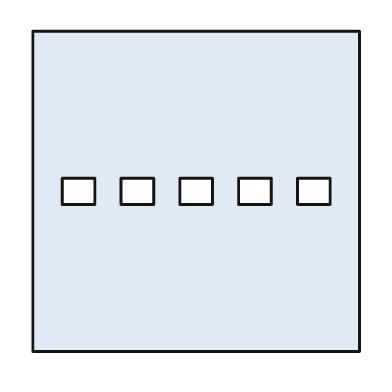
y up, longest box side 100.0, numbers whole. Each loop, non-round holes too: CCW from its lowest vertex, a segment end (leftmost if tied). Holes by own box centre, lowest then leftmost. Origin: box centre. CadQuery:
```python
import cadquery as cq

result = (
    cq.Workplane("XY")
    .moveTo(-50.0, -49.0)
    .lineTo(50.0, -49.0)
    .lineTo(50.0, 49.0)
    .lineTo(-50.0, 49.0)
    .close()
    .moveTo(-41.0, -4.0)
    .lineTo(-31.0, -4.0)
    .lineTo(-31.0, 4.0)
    .lineTo(-41.0, 4.0)
    .close()
    .moveTo(-23.0, -4.0)
    .lineTo(-13.0, -4.0)
    .lineTo(-13.0, 4.0)
    .lineTo(-23.0, 4.0)
    .close()
    .moveTo(-5.0, -4.0)
    .lineTo(5.0, -4.0)
    .lineTo(5.0, 4.0)
    .lineTo(-5.0, 4.0)
    .close()
    .moveTo(13.0, -4.0)
    .lineTo(23.0, -4.0)
    .lineTo(23.0, 4.0)
    .lineTo(13.0, 4.0)
    .close()
    .moveTo(31.0, -4.0)
    .lineTo(41.0, -4.0)
    .lineTo(41.0, 4.0)
    .lineTo(31.0, 4.0)
    .close()
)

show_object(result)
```